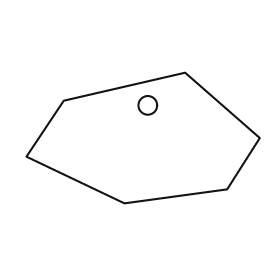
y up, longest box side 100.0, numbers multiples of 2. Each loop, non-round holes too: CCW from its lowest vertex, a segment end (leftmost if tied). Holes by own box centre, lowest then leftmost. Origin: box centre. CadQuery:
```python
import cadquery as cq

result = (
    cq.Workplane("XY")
    .moveTo(-8.0, -28.0)
    .lineTo(36.0, -22.0)
    .lineTo(50.0, 0.0)
    .lineTo(18.0, 28.0)
    .lineTo(-34.0, 16.0)
    .lineTo(-50.0, -8.0)
    .close()
    .moveTo(2.0, 14.0)
    .circle(4.0)
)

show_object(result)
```